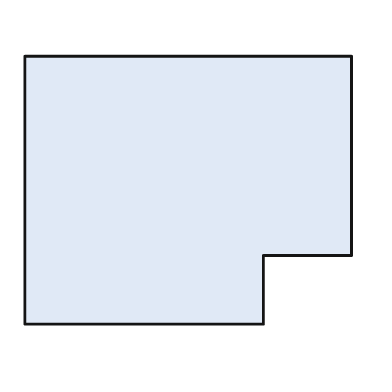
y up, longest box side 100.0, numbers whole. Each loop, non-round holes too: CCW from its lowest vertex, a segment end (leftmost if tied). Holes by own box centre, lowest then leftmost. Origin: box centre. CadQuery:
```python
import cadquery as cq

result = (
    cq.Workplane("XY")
    .moveTo(-50.0, -41.0)
    .lineTo(23.0, -41.0)
    .lineTo(23.0, -20.0)
    .lineTo(50.0, -20.0)
    .lineTo(50.0, 41.0)
    .lineTo(-50.0, 41.0)
    .close()
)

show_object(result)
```